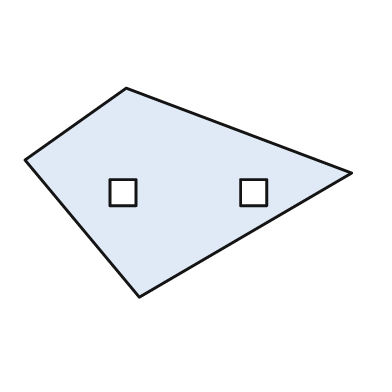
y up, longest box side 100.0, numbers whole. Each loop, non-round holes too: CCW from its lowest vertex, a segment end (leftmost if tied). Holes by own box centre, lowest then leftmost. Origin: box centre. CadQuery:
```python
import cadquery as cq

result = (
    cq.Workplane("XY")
    .moveTo(-15.0, -32.0)
    .lineTo(50.0, 6.0)
    .lineTo(-19.0, 32.0)
    .lineTo(-50.0, 10.0)
    .close()
    .moveTo(-24.0, -4.0)
    .lineTo(-16.0, -4.0)
    .lineTo(-16.0, 4.0)
    .lineTo(-24.0, 4.0)
    .close()
    .moveTo(16.0, -4.0)
    .lineTo(24.0, -4.0)
    .lineTo(24.0, 4.0)
    .lineTo(16.0, 4.0)
    .close()
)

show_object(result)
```